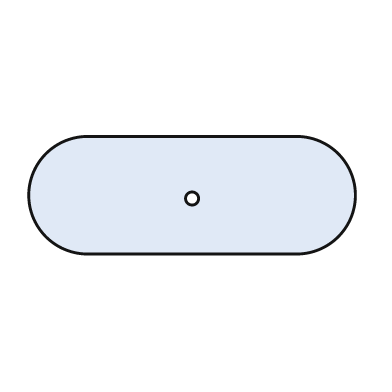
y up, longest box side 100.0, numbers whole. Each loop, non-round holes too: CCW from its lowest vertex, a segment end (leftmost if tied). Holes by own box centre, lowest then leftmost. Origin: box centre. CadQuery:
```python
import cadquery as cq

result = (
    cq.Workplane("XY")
    .moveTo(-32.0, -18.0)
    .lineTo(32.0, -18.0)
    .threePointArc((50.0, 0.0), (32.0, 18.0))
    .lineTo(-32.0, 18.0)
    .threePointArc((-50.0, 0.0), (-32.0, -18.0))
    .close()
    .moveTo(0.0, -1.0)
    .circle(2.0)
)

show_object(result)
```